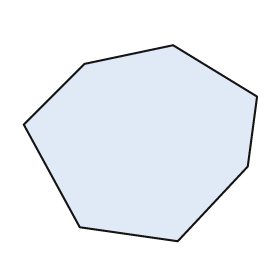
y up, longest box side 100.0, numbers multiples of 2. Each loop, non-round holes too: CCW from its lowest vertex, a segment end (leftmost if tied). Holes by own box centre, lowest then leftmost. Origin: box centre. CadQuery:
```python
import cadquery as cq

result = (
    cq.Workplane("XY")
    .moveTo(16.0, -42.0)
    .lineTo(46.0, -10.0)
    .lineTo(50.0, 20.0)
    .lineTo(14.0, 42.0)
    .lineTo(-24.0, 34.0)
    .lineTo(-50.0, 8.0)
    .lineTo(-26.0, -36.0)
    .close()
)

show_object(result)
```